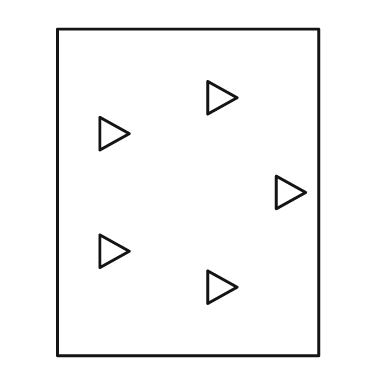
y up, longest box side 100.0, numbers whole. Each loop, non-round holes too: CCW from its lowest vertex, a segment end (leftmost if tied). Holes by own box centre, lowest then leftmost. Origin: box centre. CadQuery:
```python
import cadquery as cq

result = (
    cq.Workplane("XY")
    .moveTo(-40.0, -50.0)
    .lineTo(40.0, -50.0)
    .lineTo(40.0, 50.0)
    .lineTo(-40.0, 50.0)
    .close()
    .moveTo(6.0, -34.0)
    .lineTo(15.0, -29.0)
    .lineTo(6.0, -24.0)
    .close()
    .moveTo(-27.0, -23.0)
    .lineTo(-18.0, -18.0)
    .lineTo(-27.0, -13.0)
    .close()
    .moveTo(27.0, -5.0)
    .lineTo(36.0, 0.0)
    .lineTo(27.0, 5.0)
    .close()
    .moveTo(-27.0, 13.0)
    .lineTo(-18.0, 18.0)
    .lineTo(-27.0, 23.0)
    .close()
    .moveTo(6.0, 24.0)
    .lineTo(15.0, 29.0)
    .lineTo(6.0, 34.0)
    .close()
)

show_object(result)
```